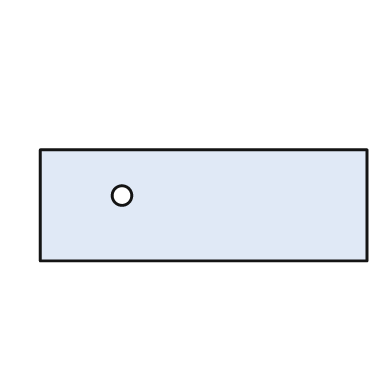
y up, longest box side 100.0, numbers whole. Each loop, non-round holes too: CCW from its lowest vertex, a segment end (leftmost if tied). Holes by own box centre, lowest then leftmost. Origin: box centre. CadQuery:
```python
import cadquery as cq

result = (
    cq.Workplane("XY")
    .moveTo(-50.0, -17.0)
    .lineTo(50.0, -17.0)
    .lineTo(50.0, 17.0)
    .lineTo(-50.0, 17.0)
    .close()
    .moveTo(-25.0, 3.0)
    .circle(3.0)
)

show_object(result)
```